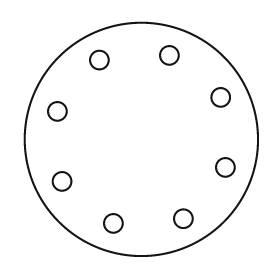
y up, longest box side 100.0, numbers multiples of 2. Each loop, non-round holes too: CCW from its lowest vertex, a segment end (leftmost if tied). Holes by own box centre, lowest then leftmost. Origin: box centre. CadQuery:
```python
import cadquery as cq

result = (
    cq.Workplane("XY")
    .moveTo(0.0, 0.0)
    .circle(50.0)
    .moveTo(-12.0, -36.0)
    .circle(4.0)
    .moveTo(18.0, -34.0)
    .circle(4.0)
    .moveTo(-34.0, -18.0)
    .circle(4.0)
    .moveTo(36.0, -12.0)
    .circle(4.0)
    .moveTo(-36.0, 12.0)
    .circle(4.0)
    .moveTo(34.0, 18.0)
    .circle(4.0)
    .moveTo(-18.0, 34.0)
    .circle(4.0)
    .moveTo(12.0, 36.0)
    .circle(4.0)
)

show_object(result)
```